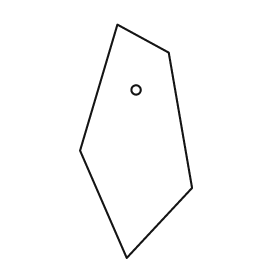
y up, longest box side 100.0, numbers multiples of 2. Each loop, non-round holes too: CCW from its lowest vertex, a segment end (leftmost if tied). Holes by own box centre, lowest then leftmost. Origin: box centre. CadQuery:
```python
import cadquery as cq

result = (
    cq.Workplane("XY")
    .moveTo(-4.0, -50.0)
    .lineTo(24.0, -20.0)
    .lineTo(14.0, 38.0)
    .lineTo(-8.0, 50.0)
    .lineTo(-24.0, -4.0)
    .close()
    .moveTo(0.0, 22.0)
    .circle(2.0)
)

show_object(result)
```